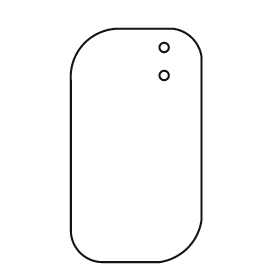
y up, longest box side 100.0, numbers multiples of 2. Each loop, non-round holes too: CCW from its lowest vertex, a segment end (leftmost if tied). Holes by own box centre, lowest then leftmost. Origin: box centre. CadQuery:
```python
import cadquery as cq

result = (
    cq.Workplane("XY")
    .moveTo(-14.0, -50.0)
    .lineTo(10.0, -50.0)
    .threePointArc((22.0, -44.0), (28.0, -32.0))
    .lineTo(28.0, 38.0)
    .threePointArc((24.0, 46.0), (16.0, 50.0))
    .lineTo(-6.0, 50.0)
    .threePointArc((-22.0, 44.0), (-28.0, 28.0))
    .lineTo(-28.0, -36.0)
    .threePointArc((-24.0, -46.0), (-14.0, -50.0))
    .close()
    .moveTo(12.0, 30.0)
    .circle(2.0)
    .moveTo(12.0, 42.0)
    .circle(2.0)
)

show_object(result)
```